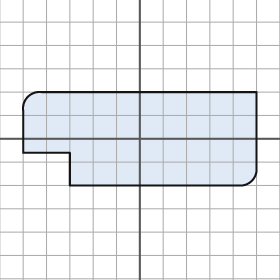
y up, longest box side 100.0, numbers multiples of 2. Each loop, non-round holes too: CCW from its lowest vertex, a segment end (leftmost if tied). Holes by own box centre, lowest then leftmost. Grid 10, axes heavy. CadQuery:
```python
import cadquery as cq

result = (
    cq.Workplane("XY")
    .moveTo(-30.0, -20.0)
    .lineTo(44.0, -20.0)
    .threePointArc((48.0, -18.0), (50.0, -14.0))
    .lineTo(50.0, 20.0)
    .lineTo(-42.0, 20.0)
    .threePointArc((-48.0, 18.0), (-50.0, 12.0))
    .lineTo(-50.0, -6.0)
    .lineTo(-30.0, -6.0)
    .close()
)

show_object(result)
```